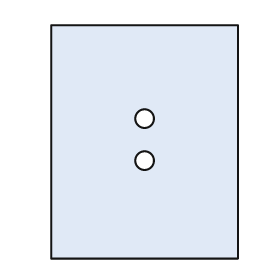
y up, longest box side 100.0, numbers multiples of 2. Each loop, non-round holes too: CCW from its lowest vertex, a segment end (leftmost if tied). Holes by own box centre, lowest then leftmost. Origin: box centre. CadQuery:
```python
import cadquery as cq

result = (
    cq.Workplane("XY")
    .moveTo(-40.0, -50.0)
    .lineTo(40.0, -50.0)
    .lineTo(40.0, 50.0)
    .lineTo(-40.0, 50.0)
    .close()
    .moveTo(0.0, -8.0)
    .circle(4.0)
    .moveTo(0.0, 10.0)
    .circle(4.0)
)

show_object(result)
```